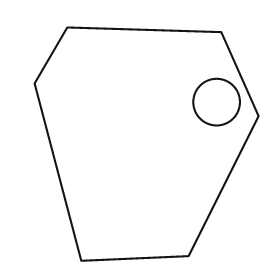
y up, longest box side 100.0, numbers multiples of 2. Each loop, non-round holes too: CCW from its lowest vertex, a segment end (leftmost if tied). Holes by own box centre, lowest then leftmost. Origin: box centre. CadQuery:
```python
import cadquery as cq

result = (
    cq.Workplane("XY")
    .moveTo(-28.0, -50.0)
    .lineTo(18.0, -48.0)
    .lineTo(48.0, 12.0)
    .lineTo(32.0, 48.0)
    .lineTo(-34.0, 50.0)
    .lineTo(-48.0, 26.0)
    .close()
    .moveTo(30.0, 18.0)
    .circle(10.0)
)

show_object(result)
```